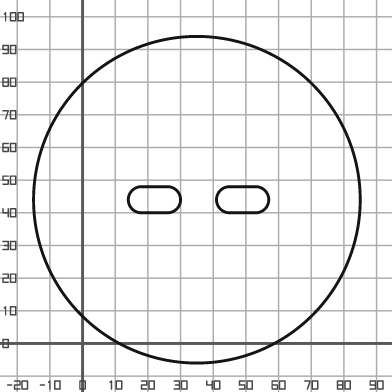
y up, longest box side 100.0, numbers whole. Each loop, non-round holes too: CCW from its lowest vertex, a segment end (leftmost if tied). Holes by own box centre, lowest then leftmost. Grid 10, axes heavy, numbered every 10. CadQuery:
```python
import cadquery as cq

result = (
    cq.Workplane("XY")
    .moveTo(35.0, 44.0)
    .circle(50.0)
    .moveTo(18.0, 40.0)
    .lineTo(26.0, 40.0)
    .threePointArc((30.0, 44.0), (26.0, 48.0))
    .lineTo(18.0, 48.0)
    .threePointArc((14.0, 44.0), (18.0, 40.0))
    .close()
    .moveTo(45.0, 40.0)
    .lineTo(53.0, 40.0)
    .threePointArc((57.0, 44.0), (53.0, 48.0))
    .lineTo(45.0, 48.0)
    .threePointArc((41.0, 44.0), (45.0, 40.0))
    .close()
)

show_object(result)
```